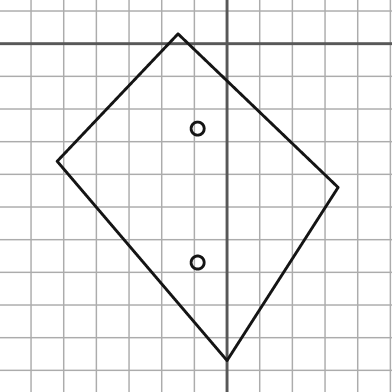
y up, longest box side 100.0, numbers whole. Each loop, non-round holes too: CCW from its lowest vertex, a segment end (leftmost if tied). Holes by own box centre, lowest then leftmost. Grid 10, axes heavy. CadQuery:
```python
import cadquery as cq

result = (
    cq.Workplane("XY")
    .moveTo(0.0, -97.0)
    .lineTo(34.0, -44.0)
    .lineTo(-15.0, 3.0)
    .lineTo(-52.0, -36.0)
    .close()
    .moveTo(-9.0, -67.0)
    .circle(2.0)
    .moveTo(-9.0, -26.0)
    .circle(2.0)
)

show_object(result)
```